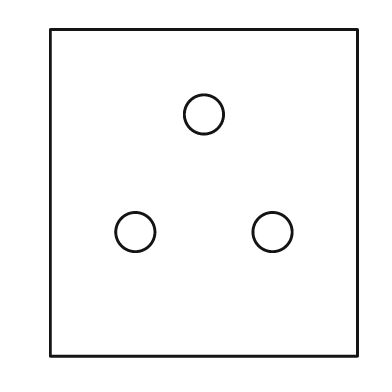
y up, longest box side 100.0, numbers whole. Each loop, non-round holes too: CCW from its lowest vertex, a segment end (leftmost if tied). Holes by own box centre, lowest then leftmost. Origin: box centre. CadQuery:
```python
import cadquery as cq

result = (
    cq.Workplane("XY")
    .moveTo(-47.0, -50.0)
    .lineTo(47.0, -50.0)
    .lineTo(47.0, 50.0)
    .lineTo(-47.0, 50.0)
    .close()
    .moveTo(-21.0, -12.0)
    .circle(6.0)
    .moveTo(21.0, -12.0)
    .circle(6.0)
    .moveTo(0.0, 24.0)
    .circle(6.0)
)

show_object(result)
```